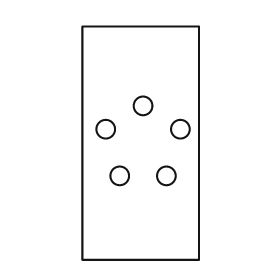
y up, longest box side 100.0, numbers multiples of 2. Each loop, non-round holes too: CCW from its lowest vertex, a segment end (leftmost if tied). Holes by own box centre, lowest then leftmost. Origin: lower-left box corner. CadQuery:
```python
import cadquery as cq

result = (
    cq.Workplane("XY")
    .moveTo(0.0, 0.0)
    .lineTo(50.0, 0.0)
    .lineTo(50.0, 100.0)
    .lineTo(0.0, 100.0)
    .close()
    .moveTo(16.0, 36.0)
    .circle(4.0)
    .moveTo(36.0, 36.0)
    .circle(4.0)
    .moveTo(10.0, 56.0)
    .circle(4.0)
    .moveTo(42.0, 56.0)
    .circle(4.0)
    .moveTo(26.0, 66.0)
    .circle(4.0)
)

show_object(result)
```